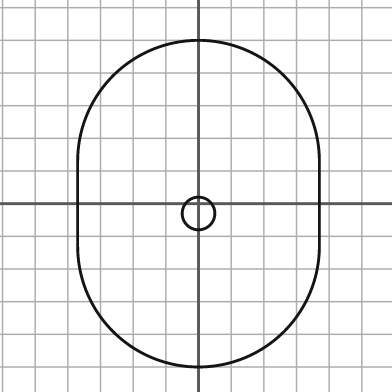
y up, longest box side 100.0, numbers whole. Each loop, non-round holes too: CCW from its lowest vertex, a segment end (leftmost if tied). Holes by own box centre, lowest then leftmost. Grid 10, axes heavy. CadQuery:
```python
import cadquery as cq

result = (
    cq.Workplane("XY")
    .moveTo(-37.0, -13.0)
    .threePointArc((0.0, -50.0), (37.0, -13.0))
    .lineTo(37.0, 13.0)
    .threePointArc((0.0, 50.0), (-37.0, 13.0))
    .close()
    .moveTo(0.0, -3.0)
    .circle(5.0)
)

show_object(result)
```